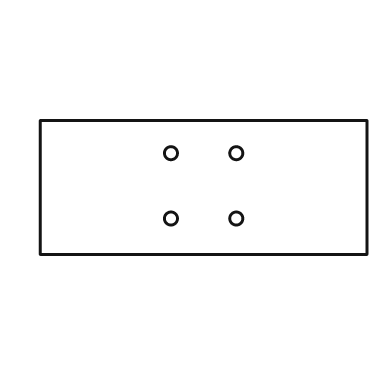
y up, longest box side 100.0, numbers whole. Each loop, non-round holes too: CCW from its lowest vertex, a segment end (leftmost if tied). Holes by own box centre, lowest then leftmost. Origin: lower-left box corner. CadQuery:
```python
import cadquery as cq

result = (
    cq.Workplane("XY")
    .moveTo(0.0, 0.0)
    .lineTo(100.0, 0.0)
    .lineTo(100.0, 41.0)
    .lineTo(0.0, 41.0)
    .close()
    .moveTo(40.0, 11.0)
    .circle(2.0)
    .moveTo(60.0, 11.0)
    .circle(2.0)
    .moveTo(40.0, 31.0)
    .circle(2.0)
    .moveTo(60.0, 31.0)
    .circle(2.0)
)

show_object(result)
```